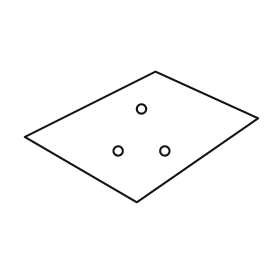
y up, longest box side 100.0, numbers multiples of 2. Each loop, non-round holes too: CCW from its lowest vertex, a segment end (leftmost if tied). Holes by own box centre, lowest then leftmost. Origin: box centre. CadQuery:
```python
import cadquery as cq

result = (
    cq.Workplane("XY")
    .moveTo(-2.0, -28.0)
    .lineTo(50.0, 8.0)
    .lineTo(6.0, 28.0)
    .lineTo(-50.0, 0.0)
    .close()
    .moveTo(-10.0, -6.0)
    .circle(2.0)
    .moveTo(10.0, -6.0)
    .circle(2.0)
    .moveTo(0.0, 12.0)
    .circle(2.0)
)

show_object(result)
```